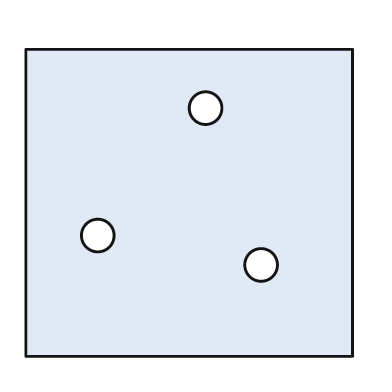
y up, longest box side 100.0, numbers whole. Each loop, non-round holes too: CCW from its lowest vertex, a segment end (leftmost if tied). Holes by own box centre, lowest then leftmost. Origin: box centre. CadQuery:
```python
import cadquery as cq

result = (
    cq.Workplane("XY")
    .moveTo(-50.0, -47.0)
    .lineTo(50.0, -47.0)
    .lineTo(50.0, 47.0)
    .lineTo(-50.0, 47.0)
    .close()
    .moveTo(22.0, -19.0)
    .circle(5.0)
    .moveTo(-28.0, -10.0)
    .circle(5.0)
    .moveTo(5.0, 29.0)
    .circle(5.0)
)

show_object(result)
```